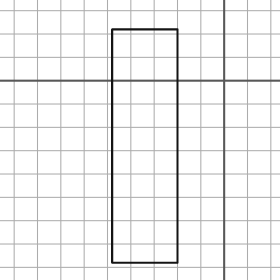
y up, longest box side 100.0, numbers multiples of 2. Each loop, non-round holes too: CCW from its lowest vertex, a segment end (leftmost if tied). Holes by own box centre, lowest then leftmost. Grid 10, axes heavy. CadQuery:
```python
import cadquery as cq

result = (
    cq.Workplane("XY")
    .moveTo(-48.0, -78.0)
    .lineTo(-20.0, -78.0)
    .lineTo(-20.0, 22.0)
    .lineTo(-48.0, 22.0)
    .close()
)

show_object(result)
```